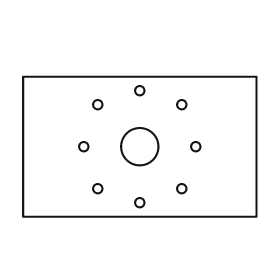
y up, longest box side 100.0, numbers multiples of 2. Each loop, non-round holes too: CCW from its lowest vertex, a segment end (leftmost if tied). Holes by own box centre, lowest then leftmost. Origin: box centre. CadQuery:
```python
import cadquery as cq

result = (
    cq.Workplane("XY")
    .moveTo(-50.0, -30.0)
    .lineTo(50.0, -30.0)
    .lineTo(50.0, 30.0)
    .lineTo(-50.0, 30.0)
    .close()
    .moveTo(0.0, -24.0)
    .circle(2.0)
    .moveTo(-18.0, -18.0)
    .circle(2.0)
    .moveTo(18.0, -18.0)
    .circle(2.0)
    .moveTo(-24.0, 0.0)
    .circle(2.0)
    .moveTo(0.0, 0.0)
    .circle(8.0)
    .moveTo(24.0, 0.0)
    .circle(2.0)
    .moveTo(-18.0, 18.0)
    .circle(2.0)
    .moveTo(18.0, 18.0)
    .circle(2.0)
    .moveTo(0.0, 24.0)
    .circle(2.0)
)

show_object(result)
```